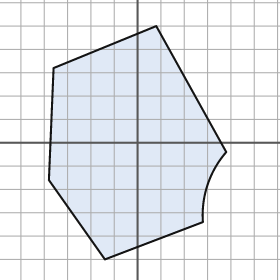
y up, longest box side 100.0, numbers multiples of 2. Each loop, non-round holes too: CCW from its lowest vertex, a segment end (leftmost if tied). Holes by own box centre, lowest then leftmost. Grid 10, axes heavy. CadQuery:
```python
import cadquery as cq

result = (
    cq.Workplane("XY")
    .moveTo(-14.0, -50.0)
    .lineTo(28.0, -34.0)
    .threePointArc((30.0, -18.0), (38.0, -4.0))
    .lineTo(8.0, 50.0)
    .lineTo(-36.0, 32.0)
    .lineTo(-38.0, -16.0)
    .close()
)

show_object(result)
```